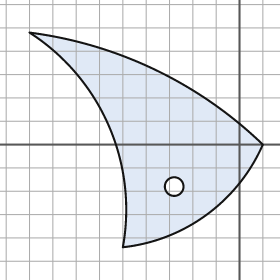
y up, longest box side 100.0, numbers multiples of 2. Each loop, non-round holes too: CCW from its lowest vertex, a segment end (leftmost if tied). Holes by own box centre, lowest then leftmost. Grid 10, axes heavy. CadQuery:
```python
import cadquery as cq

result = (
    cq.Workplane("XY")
    .moveTo(-50.0, -44.0)
    .threePointArc((-14.0, -30.0), (10.0, 0.0))
    .threePointArc((-36.0, 32.0), (-90.0, 48.0))
    .threePointArc((-56.0, 8.0), (-50.0, -44.0))
    .close()
    .moveTo(-28.0, -18.0)
    .circle(4.0)
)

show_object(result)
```